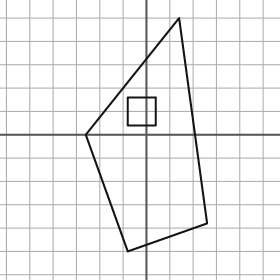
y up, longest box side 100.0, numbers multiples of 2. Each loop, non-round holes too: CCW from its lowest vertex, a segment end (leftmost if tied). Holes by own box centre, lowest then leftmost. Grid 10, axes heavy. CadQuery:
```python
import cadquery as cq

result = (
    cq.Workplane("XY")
    .moveTo(-8.0, -50.0)
    .lineTo(26.0, -38.0)
    .lineTo(14.0, 50.0)
    .lineTo(-26.0, 0.0)
    .close()
    .moveTo(-8.0, 4.0)
    .lineTo(4.0, 4.0)
    .lineTo(4.0, 16.0)
    .lineTo(-8.0, 16.0)
    .close()
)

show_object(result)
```